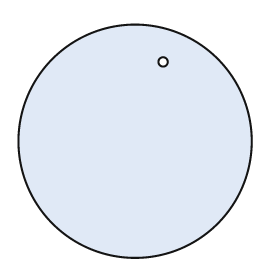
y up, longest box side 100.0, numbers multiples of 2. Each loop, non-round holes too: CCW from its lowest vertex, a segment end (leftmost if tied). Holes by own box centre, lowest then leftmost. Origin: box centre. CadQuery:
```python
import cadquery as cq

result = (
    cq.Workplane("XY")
    .moveTo(0.0, 0.0)
    .circle(50.0)
    .moveTo(12.0, 34.0)
    .circle(2.0)
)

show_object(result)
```